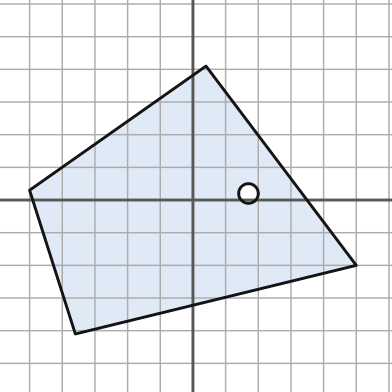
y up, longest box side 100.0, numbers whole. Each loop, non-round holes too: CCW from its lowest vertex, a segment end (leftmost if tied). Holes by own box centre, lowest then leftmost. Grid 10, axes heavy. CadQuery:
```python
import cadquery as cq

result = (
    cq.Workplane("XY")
    .moveTo(-36.0, -41.0)
    .lineTo(50.0, -20.0)
    .lineTo(4.0, 41.0)
    .lineTo(-50.0, 3.0)
    .close()
    .moveTo(17.0, 2.0)
    .circle(3.0)
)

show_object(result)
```